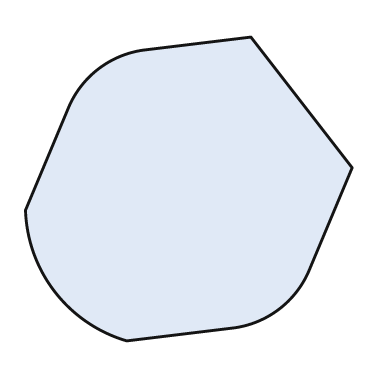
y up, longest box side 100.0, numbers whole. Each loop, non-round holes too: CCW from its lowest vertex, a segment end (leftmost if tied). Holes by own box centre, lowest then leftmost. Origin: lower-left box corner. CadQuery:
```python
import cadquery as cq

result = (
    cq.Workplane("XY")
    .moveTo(31.0, 0.0)
    .lineTo(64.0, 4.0)
    .threePointArc((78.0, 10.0), (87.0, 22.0))
    .lineTo(100.0, 53.0)
    .lineTo(69.0, 93.0)
    .lineTo(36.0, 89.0)
    .threePointArc((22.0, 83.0), (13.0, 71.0))
    .lineTo(0.0, 40.0)
    .threePointArc((9.0, 15.0), (31.0, 0.0))
    .close()
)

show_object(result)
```